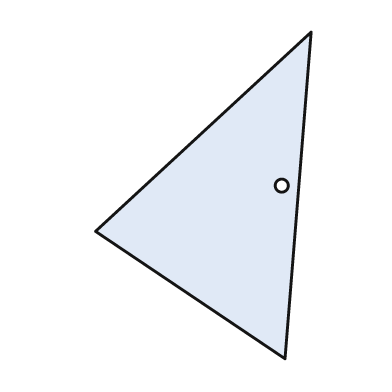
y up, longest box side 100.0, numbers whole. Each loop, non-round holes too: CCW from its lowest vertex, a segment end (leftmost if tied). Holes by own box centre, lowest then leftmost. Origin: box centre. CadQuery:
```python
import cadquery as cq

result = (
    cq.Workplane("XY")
    .moveTo(25.0, -50.0)
    .lineTo(33.0, 50.0)
    .lineTo(-33.0, -11.0)
    .close()
    .moveTo(24.0, 3.0)
    .circle(2.0)
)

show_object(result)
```